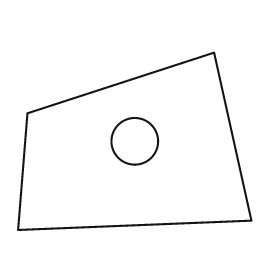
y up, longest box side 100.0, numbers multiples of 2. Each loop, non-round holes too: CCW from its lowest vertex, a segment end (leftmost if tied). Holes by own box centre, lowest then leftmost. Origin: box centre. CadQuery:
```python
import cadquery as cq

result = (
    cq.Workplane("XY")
    .moveTo(-50.0, -38.0)
    .lineTo(50.0, -34.0)
    .lineTo(34.0, 38.0)
    .lineTo(-46.0, 12.0)
    .close()
    .moveTo(0.0, 0.0)
    .circle(10.0)
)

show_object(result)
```